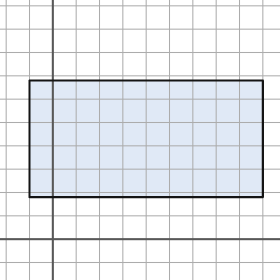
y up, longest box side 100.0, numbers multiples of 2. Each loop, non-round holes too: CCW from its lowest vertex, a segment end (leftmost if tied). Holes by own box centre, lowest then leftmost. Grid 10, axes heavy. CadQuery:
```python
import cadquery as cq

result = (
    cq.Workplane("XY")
    .moveTo(-10.0, 18.0)
    .lineTo(90.0, 18.0)
    .lineTo(90.0, 68.0)
    .lineTo(-10.0, 68.0)
    .close()
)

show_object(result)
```